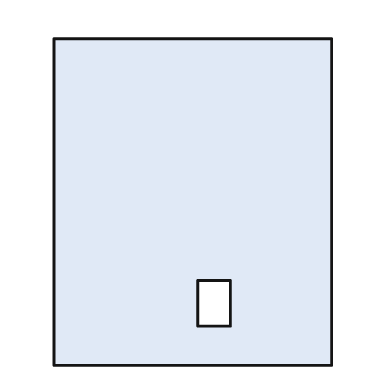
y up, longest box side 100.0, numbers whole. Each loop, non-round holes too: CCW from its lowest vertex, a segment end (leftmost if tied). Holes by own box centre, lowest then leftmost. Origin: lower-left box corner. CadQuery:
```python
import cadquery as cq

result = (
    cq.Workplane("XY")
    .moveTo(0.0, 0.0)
    .lineTo(85.0, 0.0)
    .lineTo(85.0, 100.0)
    .lineTo(0.0, 100.0)
    .close()
    .moveTo(44.0, 12.0)
    .lineTo(54.0, 12.0)
    .lineTo(54.0, 26.0)
    .lineTo(44.0, 26.0)
    .close()
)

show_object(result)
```